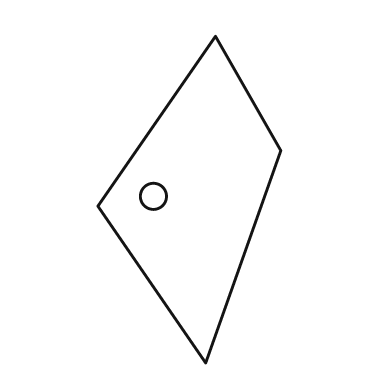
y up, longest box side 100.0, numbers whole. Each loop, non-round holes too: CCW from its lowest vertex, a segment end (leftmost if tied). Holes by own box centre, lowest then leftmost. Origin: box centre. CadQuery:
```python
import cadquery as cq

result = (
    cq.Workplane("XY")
    .moveTo(5.0, -50.0)
    .lineTo(28.0, 15.0)
    .lineTo(8.0, 50.0)
    .lineTo(-28.0, -2.0)
    .close()
    .moveTo(-11.0, 1.0)
    .circle(4.0)
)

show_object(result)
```